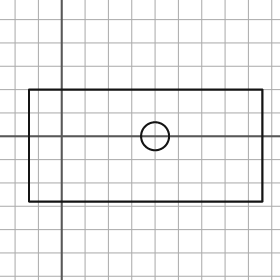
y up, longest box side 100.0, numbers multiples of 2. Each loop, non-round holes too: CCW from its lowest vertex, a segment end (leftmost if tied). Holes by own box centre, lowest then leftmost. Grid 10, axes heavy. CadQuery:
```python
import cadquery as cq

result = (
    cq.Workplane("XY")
    .moveTo(-14.0, -28.0)
    .lineTo(86.0, -28.0)
    .lineTo(86.0, 20.0)
    .lineTo(-14.0, 20.0)
    .close()
    .moveTo(40.0, 0.0)
    .circle(6.0)
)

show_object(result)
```